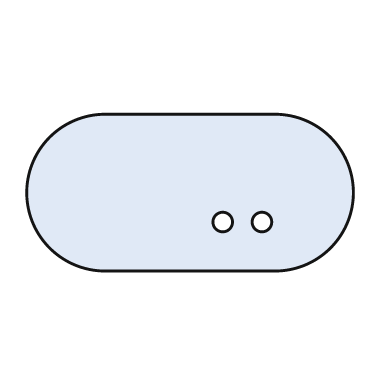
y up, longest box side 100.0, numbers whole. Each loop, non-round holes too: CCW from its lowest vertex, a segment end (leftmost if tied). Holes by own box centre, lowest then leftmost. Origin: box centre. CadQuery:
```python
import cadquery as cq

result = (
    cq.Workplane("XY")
    .moveTo(-26.0, -24.0)
    .lineTo(26.0, -24.0)
    .threePointArc((50.0, 0.0), (26.0, 24.0))
    .lineTo(-26.0, 24.0)
    .threePointArc((-50.0, 0.0), (-26.0, -24.0))
    .close()
    .moveTo(10.0, -9.0)
    .circle(3.0)
    .moveTo(22.0, -9.0)
    .circle(3.0)
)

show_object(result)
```